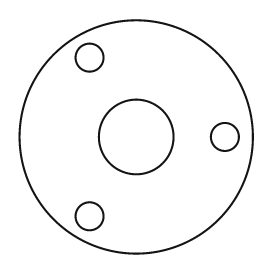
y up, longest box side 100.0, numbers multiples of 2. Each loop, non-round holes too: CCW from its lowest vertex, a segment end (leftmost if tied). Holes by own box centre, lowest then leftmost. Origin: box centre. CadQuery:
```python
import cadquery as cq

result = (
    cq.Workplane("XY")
    .moveTo(0.0, 0.0)
    .circle(50.0)
    .moveTo(-20.0, -34.0)
    .circle(6.0)
    .moveTo(0.0, 0.0)
    .circle(16.0)
    .moveTo(38.0, 0.0)
    .circle(6.0)
    .moveTo(-20.0, 34.0)
    .circle(6.0)
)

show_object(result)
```